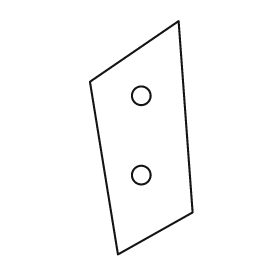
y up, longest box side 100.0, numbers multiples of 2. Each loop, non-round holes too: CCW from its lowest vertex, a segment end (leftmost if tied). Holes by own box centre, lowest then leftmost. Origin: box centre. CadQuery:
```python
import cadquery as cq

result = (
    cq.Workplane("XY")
    .moveTo(-10.0, -50.0)
    .lineTo(22.0, -32.0)
    .lineTo(16.0, 50.0)
    .lineTo(-22.0, 24.0)
    .close()
    .moveTo(0.0, -16.0)
    .circle(4.0)
    .moveTo(0.0, 18.0)
    .circle(4.0)
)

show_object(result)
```